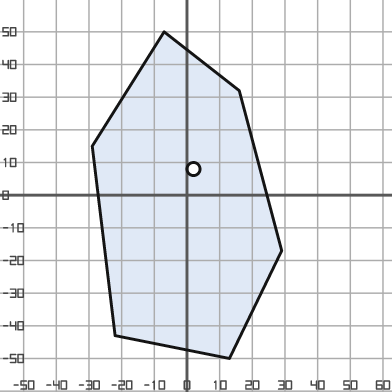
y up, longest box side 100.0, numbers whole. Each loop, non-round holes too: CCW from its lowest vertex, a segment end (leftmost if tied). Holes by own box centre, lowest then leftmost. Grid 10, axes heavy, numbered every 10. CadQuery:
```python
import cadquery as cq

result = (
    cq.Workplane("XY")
    .moveTo(13.0, -50.0)
    .lineTo(29.0, -17.0)
    .lineTo(16.0, 32.0)
    .lineTo(-7.0, 50.0)
    .lineTo(-29.0, 15.0)
    .lineTo(-22.0, -43.0)
    .close()
    .moveTo(2.0, 8.0)
    .circle(2.0)
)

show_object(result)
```